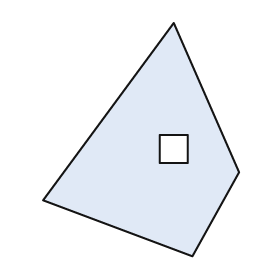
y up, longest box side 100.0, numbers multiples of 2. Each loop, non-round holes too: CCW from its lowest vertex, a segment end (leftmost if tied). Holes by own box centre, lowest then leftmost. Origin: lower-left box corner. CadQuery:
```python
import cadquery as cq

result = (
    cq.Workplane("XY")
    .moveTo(64.0, 0.0)
    .lineTo(84.0, 36.0)
    .lineTo(56.0, 100.0)
    .lineTo(0.0, 24.0)
    .close()
    .moveTo(50.0, 40.0)
    .lineTo(62.0, 40.0)
    .lineTo(62.0, 52.0)
    .lineTo(50.0, 52.0)
    .close()
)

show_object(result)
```